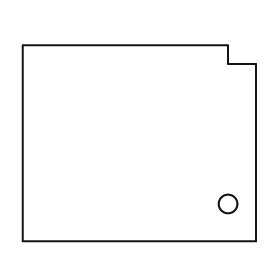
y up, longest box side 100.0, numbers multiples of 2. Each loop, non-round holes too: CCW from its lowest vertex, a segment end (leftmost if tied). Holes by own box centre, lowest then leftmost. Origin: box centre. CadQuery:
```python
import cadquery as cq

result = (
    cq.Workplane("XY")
    .moveTo(-50.0, -42.0)
    .lineTo(50.0, -42.0)
    .lineTo(50.0, 34.0)
    .lineTo(38.0, 34.0)
    .lineTo(38.0, 42.0)
    .lineTo(-50.0, 42.0)
    .close()
    .moveTo(38.0, -26.0)
    .circle(4.0)
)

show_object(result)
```